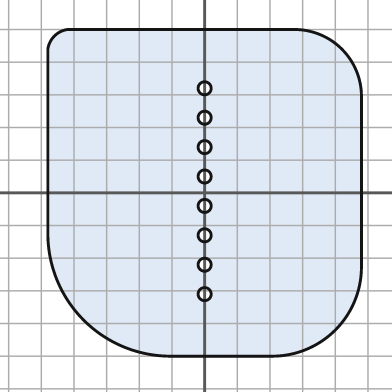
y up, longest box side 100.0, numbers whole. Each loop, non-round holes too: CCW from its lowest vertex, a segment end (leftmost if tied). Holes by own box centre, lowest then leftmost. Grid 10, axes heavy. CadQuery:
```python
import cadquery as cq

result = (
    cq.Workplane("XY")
    .moveTo(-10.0, -50.0)
    .lineTo(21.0, -50.0)
    .threePointArc((40.0, -42.0), (48.0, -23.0))
    .lineTo(48.0, 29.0)
    .threePointArc((42.0, 44.0), (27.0, 50.0))
    .lineTo(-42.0, 50.0)
    .threePointArc((-46.0, 48.0), (-48.0, 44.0))
    .lineTo(-48.0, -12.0)
    .threePointArc((-37.0, -39.0), (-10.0, -50.0))
    .close()
    .moveTo(0.0, -31.0)
    .circle(2.0)
    .moveTo(0.0, -22.0)
    .circle(2.0)
    .moveTo(0.0, -13.0)
    .circle(2.0)
    .moveTo(0.0, -4.0)
    .circle(2.0)
    .moveTo(0.0, 5.0)
    .circle(2.0)
    .moveTo(0.0, 14.0)
    .circle(2.0)
    .moveTo(0.0, 23.0)
    .circle(2.0)
    .moveTo(0.0, 32.0)
    .circle(2.0)
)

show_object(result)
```